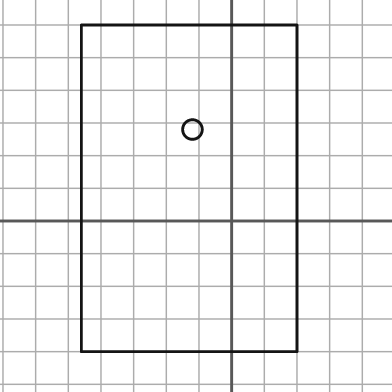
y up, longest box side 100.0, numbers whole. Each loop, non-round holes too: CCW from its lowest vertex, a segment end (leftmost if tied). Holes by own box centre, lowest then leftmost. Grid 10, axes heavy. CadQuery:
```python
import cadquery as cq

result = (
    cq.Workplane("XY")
    .moveTo(-46.0, -40.0)
    .lineTo(20.0, -40.0)
    .lineTo(20.0, 60.0)
    .lineTo(-46.0, 60.0)
    .close()
    .moveTo(-12.0, 28.0)
    .circle(3.0)
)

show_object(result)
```